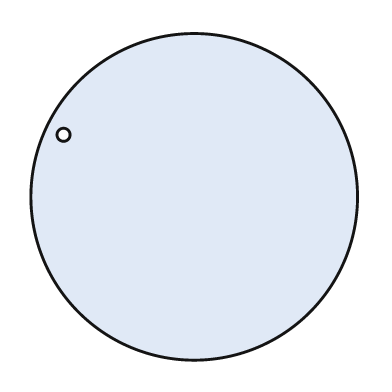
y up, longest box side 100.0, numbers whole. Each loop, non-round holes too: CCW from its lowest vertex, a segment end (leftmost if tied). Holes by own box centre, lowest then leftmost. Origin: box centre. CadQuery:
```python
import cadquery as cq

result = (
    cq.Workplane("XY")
    .moveTo(0.0, 0.0)
    .circle(50.0)
    .moveTo(-40.0, 19.0)
    .circle(2.0)
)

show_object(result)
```